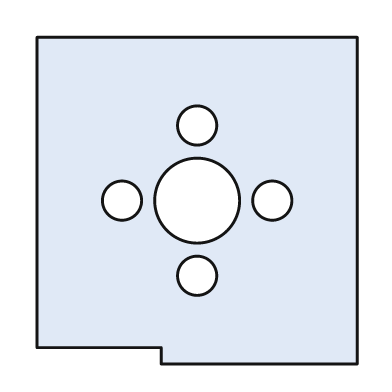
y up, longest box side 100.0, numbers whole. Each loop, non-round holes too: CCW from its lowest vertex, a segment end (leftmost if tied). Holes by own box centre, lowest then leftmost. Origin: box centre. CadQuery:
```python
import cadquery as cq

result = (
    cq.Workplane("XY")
    .moveTo(-11.0, -50.0)
    .lineTo(49.0, -50.0)
    .lineTo(49.0, 50.0)
    .lineTo(-49.0, 50.0)
    .lineTo(-49.0, -45.0)
    .lineTo(-11.0, -45.0)
    .close()
    .moveTo(0.0, -23.0)
    .circle(6.0)
    .moveTo(-23.0, 0.0)
    .circle(6.0)
    .moveTo(0.0, 0.0)
    .circle(13.0)
    .moveTo(23.0, 0.0)
    .circle(6.0)
    .moveTo(0.0, 23.0)
    .circle(6.0)
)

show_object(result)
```